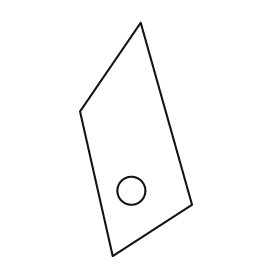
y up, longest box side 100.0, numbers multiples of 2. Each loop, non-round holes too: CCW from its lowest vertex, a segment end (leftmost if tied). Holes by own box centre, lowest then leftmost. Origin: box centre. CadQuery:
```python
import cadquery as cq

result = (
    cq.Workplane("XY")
    .moveTo(-10.0, -50.0)
    .lineTo(24.0, -28.0)
    .lineTo(2.0, 50.0)
    .lineTo(-24.0, 12.0)
    .close()
    .moveTo(-2.0, -22.0)
    .circle(6.0)
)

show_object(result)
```